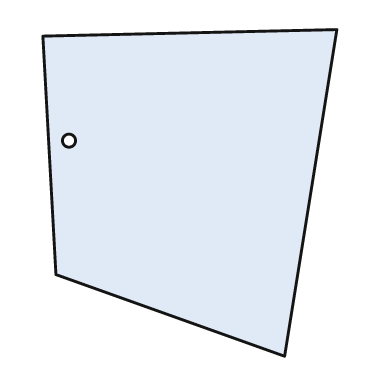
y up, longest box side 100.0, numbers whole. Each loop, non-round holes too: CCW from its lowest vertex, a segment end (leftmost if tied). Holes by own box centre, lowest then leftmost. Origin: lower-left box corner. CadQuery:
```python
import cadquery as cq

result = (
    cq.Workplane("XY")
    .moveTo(74.0, 0.0)
    .lineTo(90.0, 100.0)
    .lineTo(0.0, 98.0)
    .lineTo(4.0, 25.0)
    .close()
    .moveTo(8.0, 66.0)
    .circle(2.0)
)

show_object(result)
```